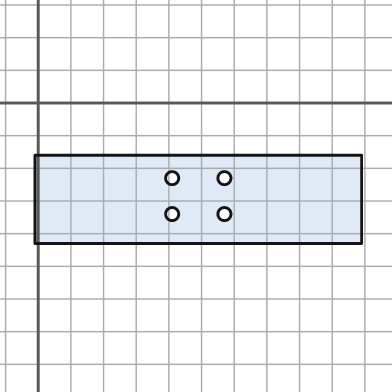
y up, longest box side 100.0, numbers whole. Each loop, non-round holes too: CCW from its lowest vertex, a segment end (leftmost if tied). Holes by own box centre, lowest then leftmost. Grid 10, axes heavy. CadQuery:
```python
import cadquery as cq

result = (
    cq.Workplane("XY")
    .moveTo(-1.0, -43.0)
    .lineTo(99.0, -43.0)
    .lineTo(99.0, -16.0)
    .lineTo(-1.0, -16.0)
    .close()
    .moveTo(41.0, -34.0)
    .circle(2.0)
    .moveTo(57.0, -34.0)
    .circle(2.0)
    .moveTo(41.0, -23.0)
    .circle(2.0)
    .moveTo(57.0, -23.0)
    .circle(2.0)
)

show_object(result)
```